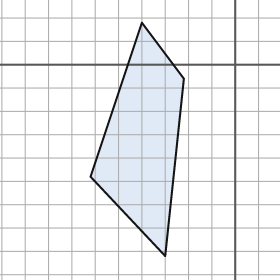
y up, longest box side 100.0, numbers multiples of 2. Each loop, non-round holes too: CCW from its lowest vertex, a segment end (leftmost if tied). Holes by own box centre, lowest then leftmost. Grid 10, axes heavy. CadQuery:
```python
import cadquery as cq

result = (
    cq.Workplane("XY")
    .moveTo(-30.0, -82.0)
    .lineTo(-22.0, -6.0)
    .lineTo(-40.0, 18.0)
    .lineTo(-62.0, -48.0)
    .close()
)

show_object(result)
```